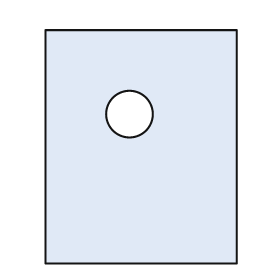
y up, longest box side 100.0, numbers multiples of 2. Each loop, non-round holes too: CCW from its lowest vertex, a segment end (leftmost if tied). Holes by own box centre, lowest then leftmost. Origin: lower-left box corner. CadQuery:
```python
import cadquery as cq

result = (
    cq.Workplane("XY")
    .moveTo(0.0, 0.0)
    .lineTo(82.0, 0.0)
    .lineTo(82.0, 100.0)
    .lineTo(0.0, 100.0)
    .close()
    .moveTo(36.0, 64.0)
    .circle(10.0)
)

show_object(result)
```